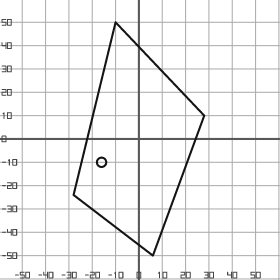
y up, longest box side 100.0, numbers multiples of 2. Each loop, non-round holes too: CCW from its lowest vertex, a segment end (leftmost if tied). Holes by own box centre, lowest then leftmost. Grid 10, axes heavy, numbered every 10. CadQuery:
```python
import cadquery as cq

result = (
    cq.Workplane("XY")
    .moveTo(6.0, -50.0)
    .lineTo(28.0, 10.0)
    .lineTo(-10.0, 50.0)
    .lineTo(-28.0, -24.0)
    .close()
    .moveTo(-16.0, -10.0)
    .circle(2.0)
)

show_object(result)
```